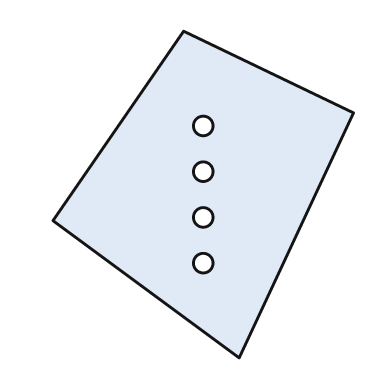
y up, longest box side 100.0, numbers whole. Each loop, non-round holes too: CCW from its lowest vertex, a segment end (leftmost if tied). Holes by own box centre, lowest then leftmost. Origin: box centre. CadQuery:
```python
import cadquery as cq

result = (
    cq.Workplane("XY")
    .moveTo(11.0, -50.0)
    .lineTo(46.0, 25.0)
    .lineTo(-6.0, 50.0)
    .lineTo(-46.0, -8.0)
    .close()
    .moveTo(0.0, -21.0)
    .circle(3.0)
    .moveTo(0.0, -7.0)
    .circle(3.0)
    .moveTo(0.0, 7.0)
    .circle(3.0)
    .moveTo(0.0, 21.0)
    .circle(3.0)
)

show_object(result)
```